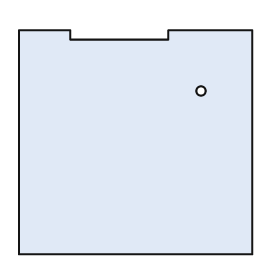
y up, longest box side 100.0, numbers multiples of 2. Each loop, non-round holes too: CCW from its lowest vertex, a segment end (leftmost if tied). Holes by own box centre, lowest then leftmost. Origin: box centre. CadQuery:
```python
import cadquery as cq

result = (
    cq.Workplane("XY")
    .moveTo(-50.0, -48.0)
    .lineTo(50.0, -48.0)
    .lineTo(50.0, 48.0)
    .lineTo(14.0, 48.0)
    .lineTo(14.0, 44.0)
    .lineTo(-28.0, 44.0)
    .lineTo(-28.0, 48.0)
    .lineTo(-50.0, 48.0)
    .close()
    .moveTo(28.0, 22.0)
    .circle(2.0)
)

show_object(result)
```